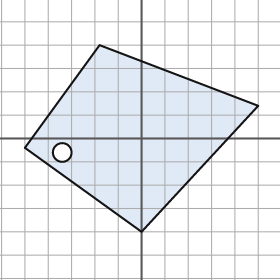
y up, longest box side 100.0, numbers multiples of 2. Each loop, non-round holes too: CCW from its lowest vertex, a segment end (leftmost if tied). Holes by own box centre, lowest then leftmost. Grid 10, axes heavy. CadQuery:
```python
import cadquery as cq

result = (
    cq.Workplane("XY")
    .moveTo(0.0, -40.0)
    .lineTo(50.0, 14.0)
    .lineTo(-18.0, 40.0)
    .lineTo(-50.0, -4.0)
    .close()
    .moveTo(-34.0, -6.0)
    .circle(4.0)
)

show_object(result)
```